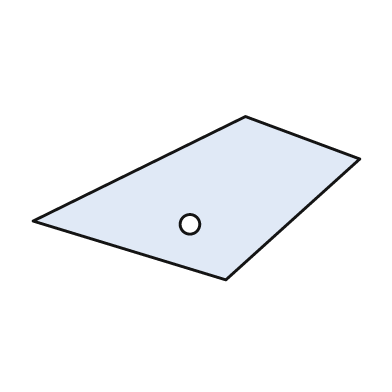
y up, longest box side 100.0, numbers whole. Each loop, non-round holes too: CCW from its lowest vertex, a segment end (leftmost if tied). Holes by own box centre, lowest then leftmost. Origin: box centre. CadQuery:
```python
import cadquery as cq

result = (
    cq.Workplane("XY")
    .moveTo(9.0, -25.0)
    .lineTo(50.0, 12.0)
    .lineTo(15.0, 25.0)
    .lineTo(-50.0, -7.0)
    .close()
    .moveTo(-2.0, -8.0)
    .circle(3.0)
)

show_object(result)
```